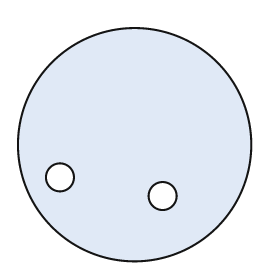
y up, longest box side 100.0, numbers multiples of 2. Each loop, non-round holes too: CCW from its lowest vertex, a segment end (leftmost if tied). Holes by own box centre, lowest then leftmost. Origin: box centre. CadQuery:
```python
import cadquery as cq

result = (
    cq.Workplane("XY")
    .moveTo(0.0, 0.0)
    .circle(50.0)
    .moveTo(12.0, -22.0)
    .circle(6.0)
    .moveTo(-32.0, -14.0)
    .circle(6.0)
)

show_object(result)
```